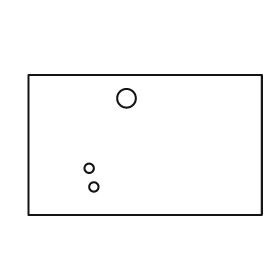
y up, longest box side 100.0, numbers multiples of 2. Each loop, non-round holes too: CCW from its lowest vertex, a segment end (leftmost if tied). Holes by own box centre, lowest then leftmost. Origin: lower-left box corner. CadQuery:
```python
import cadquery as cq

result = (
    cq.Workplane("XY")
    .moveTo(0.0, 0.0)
    .lineTo(100.0, 0.0)
    .lineTo(100.0, 60.0)
    .lineTo(0.0, 60.0)
    .close()
    .moveTo(28.0, 12.0)
    .circle(2.0)
    .moveTo(26.0, 20.0)
    .circle(2.0)
    .moveTo(42.0, 50.0)
    .circle(4.0)
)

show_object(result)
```